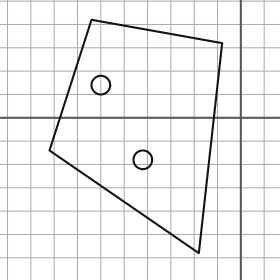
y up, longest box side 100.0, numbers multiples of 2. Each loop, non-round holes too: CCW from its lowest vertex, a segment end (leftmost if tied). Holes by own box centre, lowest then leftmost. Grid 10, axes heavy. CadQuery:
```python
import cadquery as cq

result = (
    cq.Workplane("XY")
    .moveTo(-18.0, -58.0)
    .lineTo(-8.0, 32.0)
    .lineTo(-64.0, 42.0)
    .lineTo(-82.0, -14.0)
    .close()
    .moveTo(-42.0, -18.0)
    .circle(4.0)
    .moveTo(-60.0, 14.0)
    .circle(4.0)
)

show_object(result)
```